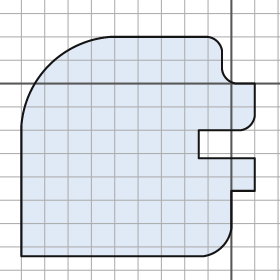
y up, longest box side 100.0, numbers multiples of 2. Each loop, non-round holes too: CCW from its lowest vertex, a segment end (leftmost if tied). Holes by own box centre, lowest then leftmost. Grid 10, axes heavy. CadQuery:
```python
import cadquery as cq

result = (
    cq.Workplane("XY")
    .moveTo(-90.0, -74.0)
    .lineTo(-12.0, -74.0)
    .threePointArc((-4.0, -70.0), (0.0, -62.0))
    .lineTo(0.0, -46.0)
    .lineTo(10.0, -46.0)
    .lineTo(10.0, -32.0)
    .lineTo(-14.0, -32.0)
    .lineTo(-14.0, -20.0)
    .lineTo(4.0, -20.0)
    .threePointArc((8.0, -18.0), (10.0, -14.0))
    .lineTo(10.0, 0.0)
    .lineTo(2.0, 0.0)
    .threePointArc((-2.0, 2.0), (-4.0, 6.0))
    .lineTo(-4.0, 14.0)
    .threePointArc((-6.0, 18.0), (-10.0, 20.0))
    .lineTo(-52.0, 20.0)
    .threePointArc((-78.0, 8.0), (-90.0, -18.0))
    .close()
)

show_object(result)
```